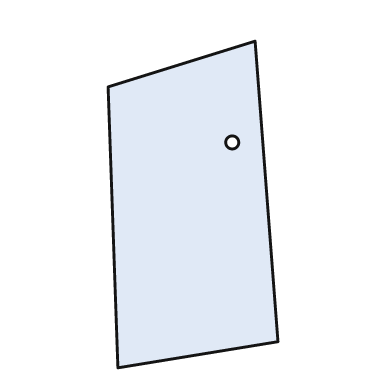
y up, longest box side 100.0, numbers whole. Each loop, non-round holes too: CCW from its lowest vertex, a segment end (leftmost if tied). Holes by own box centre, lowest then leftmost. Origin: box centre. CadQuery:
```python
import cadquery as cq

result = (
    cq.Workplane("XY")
    .moveTo(-23.0, -50.0)
    .lineTo(26.0, -42.0)
    .lineTo(19.0, 50.0)
    .lineTo(-26.0, 36.0)
    .close()
    .moveTo(12.0, 19.0)
    .circle(2.0)
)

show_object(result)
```